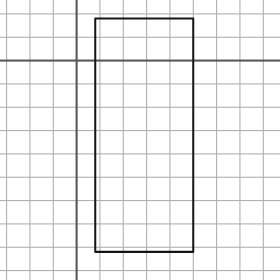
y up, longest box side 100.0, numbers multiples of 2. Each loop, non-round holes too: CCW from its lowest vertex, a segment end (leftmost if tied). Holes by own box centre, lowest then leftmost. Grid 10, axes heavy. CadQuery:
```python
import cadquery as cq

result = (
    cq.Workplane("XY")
    .moveTo(8.0, -82.0)
    .lineTo(50.0, -82.0)
    .lineTo(50.0, 18.0)
    .lineTo(8.0, 18.0)
    .close()
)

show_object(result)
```